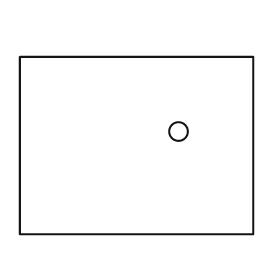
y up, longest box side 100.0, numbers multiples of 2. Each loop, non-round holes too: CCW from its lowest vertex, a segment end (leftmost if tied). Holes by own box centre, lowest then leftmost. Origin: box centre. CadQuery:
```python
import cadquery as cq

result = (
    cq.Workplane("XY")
    .moveTo(-50.0, -38.0)
    .lineTo(50.0, -38.0)
    .lineTo(50.0, 38.0)
    .lineTo(-50.0, 38.0)
    .close()
    .moveTo(18.0, 6.0)
    .circle(4.0)
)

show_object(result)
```